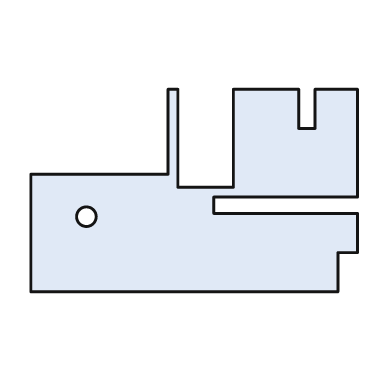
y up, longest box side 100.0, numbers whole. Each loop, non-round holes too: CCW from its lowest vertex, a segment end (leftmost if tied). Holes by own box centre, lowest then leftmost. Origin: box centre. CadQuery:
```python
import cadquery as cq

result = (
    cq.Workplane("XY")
    .moveTo(-50.0, -31.0)
    .lineTo(44.0, -31.0)
    .lineTo(44.0, -19.0)
    .lineTo(50.0, -19.0)
    .lineTo(50.0, -7.0)
    .lineTo(6.0, -7.0)
    .lineTo(6.0, -2.0)
    .lineTo(50.0, -2.0)
    .lineTo(50.0, 31.0)
    .lineTo(37.0, 31.0)
    .lineTo(37.0, 19.0)
    .lineTo(32.0, 19.0)
    .lineTo(32.0, 31.0)
    .lineTo(12.0, 31.0)
    .lineTo(12.0, 1.0)
    .lineTo(-5.0, 1.0)
    .lineTo(-5.0, 31.0)
    .lineTo(-8.0, 31.0)
    .lineTo(-8.0, 5.0)
    .lineTo(-50.0, 5.0)
    .close()
    .moveTo(-33.0, -8.0)
    .circle(3.0)
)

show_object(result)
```